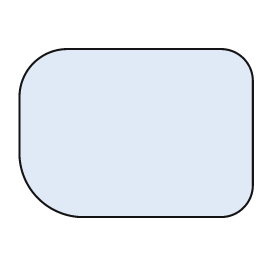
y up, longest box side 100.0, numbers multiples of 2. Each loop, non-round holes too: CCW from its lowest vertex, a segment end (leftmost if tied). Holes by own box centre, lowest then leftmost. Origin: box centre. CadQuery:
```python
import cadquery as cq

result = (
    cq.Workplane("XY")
    .moveTo(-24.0, -36.0)
    .lineTo(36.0, -36.0)
    .threePointArc((46.0, -32.0), (50.0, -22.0))
    .lineTo(50.0, 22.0)
    .threePointArc((46.0, 32.0), (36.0, 36.0))
    .lineTo(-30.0, 36.0)
    .threePointArc((-44.0, 30.0), (-50.0, 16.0))
    .lineTo(-50.0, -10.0)
    .threePointArc((-42.0, -28.0), (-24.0, -36.0))
    .close()
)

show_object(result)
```